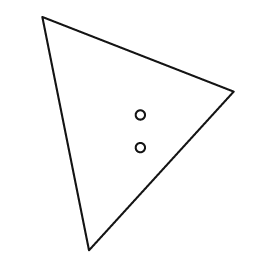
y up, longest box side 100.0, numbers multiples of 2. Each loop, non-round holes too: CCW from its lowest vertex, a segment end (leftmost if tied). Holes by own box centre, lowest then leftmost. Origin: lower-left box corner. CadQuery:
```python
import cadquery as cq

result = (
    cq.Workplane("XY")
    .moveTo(20.0, 0.0)
    .lineTo(82.0, 68.0)
    .lineTo(0.0, 100.0)
    .close()
    .moveTo(42.0, 44.0)
    .circle(2.0)
    .moveTo(42.0, 58.0)
    .circle(2.0)
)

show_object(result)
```